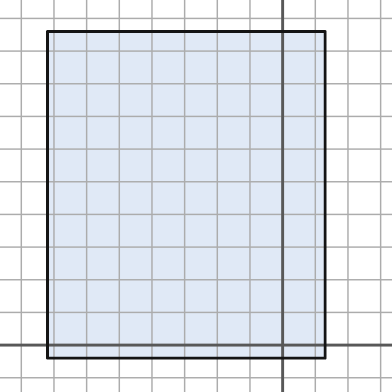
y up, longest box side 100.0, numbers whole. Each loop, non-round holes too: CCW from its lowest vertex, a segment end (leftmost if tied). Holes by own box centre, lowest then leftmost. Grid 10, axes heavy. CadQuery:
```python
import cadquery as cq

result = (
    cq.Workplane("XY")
    .moveTo(-72.0, -4.0)
    .lineTo(13.0, -4.0)
    .lineTo(13.0, 96.0)
    .lineTo(-72.0, 96.0)
    .close()
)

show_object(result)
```